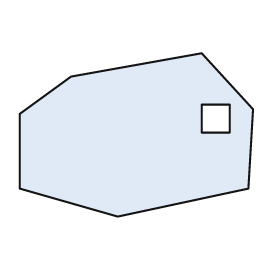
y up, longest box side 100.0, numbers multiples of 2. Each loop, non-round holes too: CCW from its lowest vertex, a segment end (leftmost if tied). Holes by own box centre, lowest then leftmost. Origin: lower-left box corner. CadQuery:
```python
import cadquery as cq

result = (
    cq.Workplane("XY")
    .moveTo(42.0, 0.0)
    .lineTo(98.0, 12.0)
    .lineTo(100.0, 46.0)
    .lineTo(78.0, 70.0)
    .lineTo(22.0, 60.0)
    .lineTo(0.0, 44.0)
    .lineTo(0.0, 12.0)
    .close()
    .moveTo(78.0, 36.0)
    .lineTo(90.0, 36.0)
    .lineTo(90.0, 48.0)
    .lineTo(78.0, 48.0)
    .close()
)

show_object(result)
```